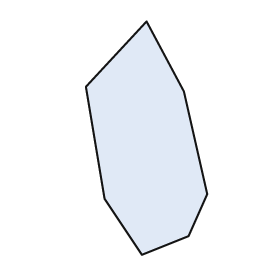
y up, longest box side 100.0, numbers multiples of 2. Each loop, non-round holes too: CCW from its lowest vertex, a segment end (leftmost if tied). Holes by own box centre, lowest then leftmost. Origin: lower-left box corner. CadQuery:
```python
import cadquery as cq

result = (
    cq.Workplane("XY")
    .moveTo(24.0, 0.0)
    .lineTo(44.0, 8.0)
    .lineTo(52.0, 26.0)
    .lineTo(42.0, 70.0)
    .lineTo(26.0, 100.0)
    .lineTo(0.0, 72.0)
    .lineTo(8.0, 24.0)
    .close()
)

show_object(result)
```